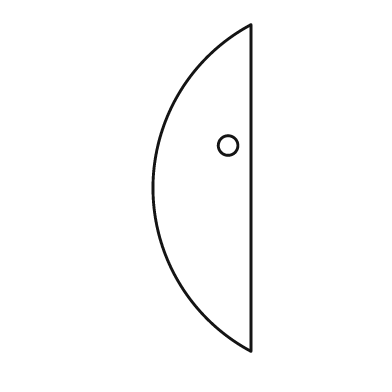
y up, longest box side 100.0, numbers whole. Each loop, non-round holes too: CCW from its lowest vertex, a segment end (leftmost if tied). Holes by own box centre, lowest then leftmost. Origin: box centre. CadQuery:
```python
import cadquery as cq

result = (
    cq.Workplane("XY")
    .moveTo(15.0, -50.0)
    .lineTo(15.0, 50.0)
    .threePointArc((-15.0, 0.0), (15.0, -50.0))
    .close()
    .moveTo(8.0, 13.0)
    .circle(3.0)
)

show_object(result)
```